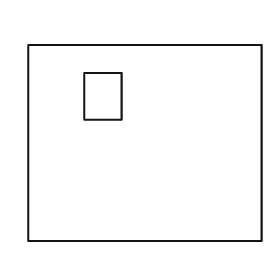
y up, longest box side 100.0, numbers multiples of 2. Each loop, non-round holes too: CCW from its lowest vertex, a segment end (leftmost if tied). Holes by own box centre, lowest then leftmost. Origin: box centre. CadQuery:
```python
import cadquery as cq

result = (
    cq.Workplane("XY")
    .moveTo(-50.0, -42.0)
    .lineTo(50.0, -42.0)
    .lineTo(50.0, 42.0)
    .lineTo(-50.0, 42.0)
    .close()
    .moveTo(-26.0, 10.0)
    .lineTo(-10.0, 10.0)
    .lineTo(-10.0, 30.0)
    .lineTo(-26.0, 30.0)
    .close()
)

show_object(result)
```